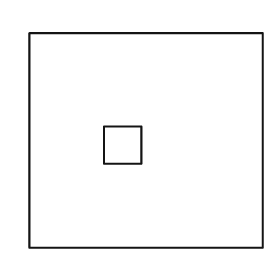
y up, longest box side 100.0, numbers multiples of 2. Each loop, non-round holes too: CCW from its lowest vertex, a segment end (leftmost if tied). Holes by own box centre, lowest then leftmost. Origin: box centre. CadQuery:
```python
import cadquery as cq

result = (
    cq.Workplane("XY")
    .moveTo(-50.0, -46.0)
    .lineTo(50.0, -46.0)
    .lineTo(50.0, 46.0)
    .lineTo(-50.0, 46.0)
    .close()
    .moveTo(-18.0, -10.0)
    .lineTo(-2.0, -10.0)
    .lineTo(-2.0, 6.0)
    .lineTo(-18.0, 6.0)
    .close()
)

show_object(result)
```